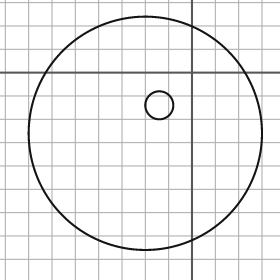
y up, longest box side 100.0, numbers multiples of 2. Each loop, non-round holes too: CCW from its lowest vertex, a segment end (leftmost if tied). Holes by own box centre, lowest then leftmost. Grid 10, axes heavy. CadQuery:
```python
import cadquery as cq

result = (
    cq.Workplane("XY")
    .moveTo(-20.0, -26.0)
    .circle(50.0)
    .moveTo(-14.0, -14.0)
    .circle(6.0)
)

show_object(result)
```